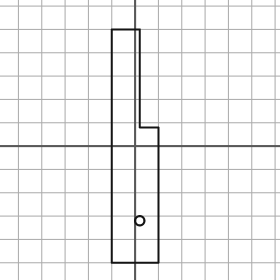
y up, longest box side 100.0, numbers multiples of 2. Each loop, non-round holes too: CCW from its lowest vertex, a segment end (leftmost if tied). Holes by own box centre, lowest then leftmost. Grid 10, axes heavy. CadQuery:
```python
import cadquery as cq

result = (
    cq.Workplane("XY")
    .moveTo(-10.0, -50.0)
    .lineTo(10.0, -50.0)
    .lineTo(10.0, 8.0)
    .lineTo(2.0, 8.0)
    .lineTo(2.0, 50.0)
    .lineTo(-10.0, 50.0)
    .close()
    .moveTo(2.0, -32.0)
    .circle(2.0)
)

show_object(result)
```